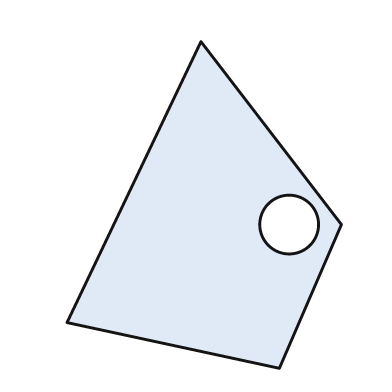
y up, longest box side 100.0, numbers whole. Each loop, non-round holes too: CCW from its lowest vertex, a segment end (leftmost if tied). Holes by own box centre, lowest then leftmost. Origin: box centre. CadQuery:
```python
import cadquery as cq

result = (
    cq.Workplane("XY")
    .moveTo(23.0, -50.0)
    .lineTo(42.0, -6.0)
    .lineTo(-1.0, 50.0)
    .lineTo(-42.0, -36.0)
    .close()
    .moveTo(26.0, -6.0)
    .circle(9.0)
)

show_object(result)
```